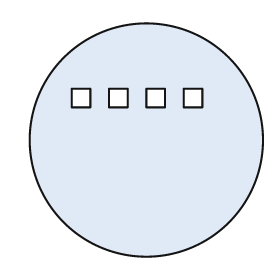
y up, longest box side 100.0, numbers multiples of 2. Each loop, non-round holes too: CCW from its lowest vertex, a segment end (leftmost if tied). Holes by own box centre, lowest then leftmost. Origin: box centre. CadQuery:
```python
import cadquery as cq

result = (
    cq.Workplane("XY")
    .moveTo(0.0, 0.0)
    .circle(50.0)
    .moveTo(-32.0, 14.0)
    .lineTo(-24.0, 14.0)
    .lineTo(-24.0, 22.0)
    .lineTo(-32.0, 22.0)
    .close()
    .moveTo(-16.0, 14.0)
    .lineTo(-8.0, 14.0)
    .lineTo(-8.0, 22.0)
    .lineTo(-16.0, 22.0)
    .close()
    .moveTo(0.0, 14.0)
    .lineTo(8.0, 14.0)
    .lineTo(8.0, 22.0)
    .lineTo(0.0, 22.0)
    .close()
    .moveTo(16.0, 14.0)
    .lineTo(24.0, 14.0)
    .lineTo(24.0, 22.0)
    .lineTo(16.0, 22.0)
    .close()
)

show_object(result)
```